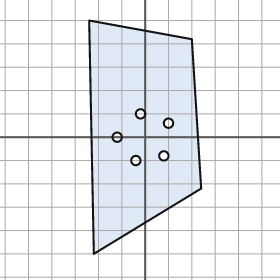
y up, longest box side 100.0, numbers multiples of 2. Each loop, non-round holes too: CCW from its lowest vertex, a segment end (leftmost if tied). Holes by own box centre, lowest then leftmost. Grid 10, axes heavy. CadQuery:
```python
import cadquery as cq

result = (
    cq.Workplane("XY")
    .moveTo(-22.0, -50.0)
    .lineTo(24.0, -22.0)
    .lineTo(20.0, 42.0)
    .lineTo(-24.0, 50.0)
    .close()
    .moveTo(-4.0, -10.0)
    .circle(2.0)
    .moveTo(8.0, -8.0)
    .circle(2.0)
    .moveTo(-12.0, 0.0)
    .circle(2.0)
    .moveTo(10.0, 6.0)
    .circle(2.0)
    .moveTo(-2.0, 10.0)
    .circle(2.0)
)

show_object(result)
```